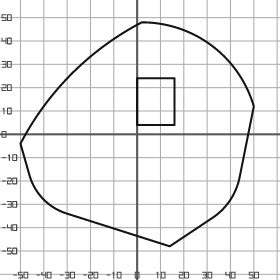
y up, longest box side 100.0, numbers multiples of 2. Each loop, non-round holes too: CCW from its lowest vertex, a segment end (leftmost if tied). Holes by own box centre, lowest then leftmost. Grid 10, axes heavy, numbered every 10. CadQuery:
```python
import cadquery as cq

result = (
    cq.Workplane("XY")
    .moveTo(14.0, -48.0)
    .lineTo(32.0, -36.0)
    .threePointArc((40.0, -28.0), (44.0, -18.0))
    .lineTo(50.0, 12.0)
    .threePointArc((32.0, 38.0), (2.0, 48.0))
    .threePointArc((-28.0, 26.0), (-50.0, -4.0))
    .lineTo(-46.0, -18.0)
    .threePointArc((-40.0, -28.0), (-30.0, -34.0))
    .close()
    .moveTo(0.0, 4.0)
    .lineTo(16.0, 4.0)
    .lineTo(16.0, 24.0)
    .lineTo(0.0, 24.0)
    .close()
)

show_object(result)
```